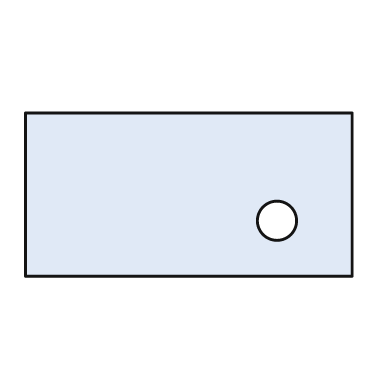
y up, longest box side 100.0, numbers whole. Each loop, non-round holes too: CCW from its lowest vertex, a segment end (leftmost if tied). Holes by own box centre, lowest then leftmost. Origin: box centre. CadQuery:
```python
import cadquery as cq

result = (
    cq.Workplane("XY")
    .moveTo(-50.0, -25.0)
    .lineTo(50.0, -25.0)
    .lineTo(50.0, 25.0)
    .lineTo(-50.0, 25.0)
    .close()
    .moveTo(27.0, -8.0)
    .circle(6.0)
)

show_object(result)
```